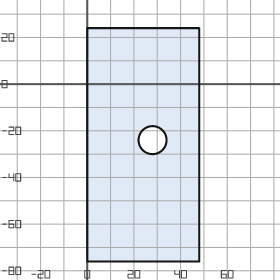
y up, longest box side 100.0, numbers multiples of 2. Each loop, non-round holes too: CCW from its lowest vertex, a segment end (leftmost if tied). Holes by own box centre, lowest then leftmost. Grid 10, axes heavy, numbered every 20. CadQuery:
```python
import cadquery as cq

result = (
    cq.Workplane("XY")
    .moveTo(0.0, -76.0)
    .lineTo(48.0, -76.0)
    .lineTo(48.0, 24.0)
    .lineTo(0.0, 24.0)
    .close()
    .moveTo(28.0, -24.0)
    .circle(6.0)
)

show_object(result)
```